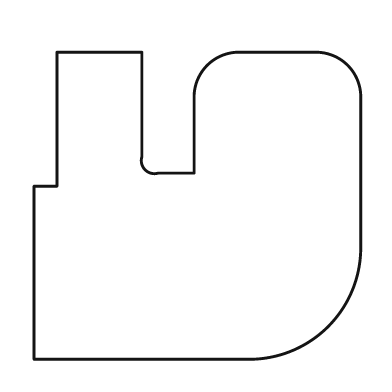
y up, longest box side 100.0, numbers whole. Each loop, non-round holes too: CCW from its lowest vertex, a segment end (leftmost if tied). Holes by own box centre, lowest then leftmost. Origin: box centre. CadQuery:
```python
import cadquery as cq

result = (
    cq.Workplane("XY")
    .moveTo(-50.0, -47.0)
    .lineTo(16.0, -47.0)
    .threePointArc((40.0, -37.0), (50.0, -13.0))
    .lineTo(50.0, 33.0)
    .threePointArc((46.0, 43.0), (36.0, 47.0))
    .lineTo(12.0, 47.0)
    .threePointArc((3.0, 43.0), (-1.0, 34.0))
    .lineTo(-1.0, 10.0)
    .lineTo(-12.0, 10.0)
    .threePointArc((-16.0, 11.0), (-17.0, 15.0))
    .lineTo(-17.0, 47.0)
    .lineTo(-43.0, 47.0)
    .lineTo(-43.0, 6.0)
    .lineTo(-50.0, 6.0)
    .close()
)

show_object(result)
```